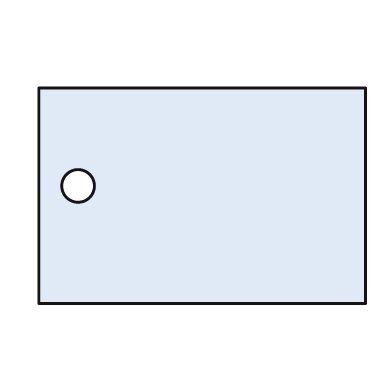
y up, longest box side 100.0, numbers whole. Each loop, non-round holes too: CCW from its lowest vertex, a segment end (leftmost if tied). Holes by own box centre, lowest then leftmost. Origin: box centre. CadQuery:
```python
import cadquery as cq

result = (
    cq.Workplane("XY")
    .moveTo(-50.0, -33.0)
    .lineTo(50.0, -33.0)
    .lineTo(50.0, 33.0)
    .lineTo(-50.0, 33.0)
    .close()
    .moveTo(-38.0, 3.0)
    .circle(5.0)
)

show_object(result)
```